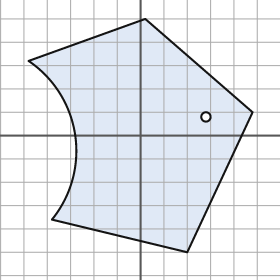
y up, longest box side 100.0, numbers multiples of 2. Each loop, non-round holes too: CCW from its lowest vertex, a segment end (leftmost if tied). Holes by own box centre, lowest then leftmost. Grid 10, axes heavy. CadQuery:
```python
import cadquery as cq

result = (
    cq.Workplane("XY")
    .moveTo(20.0, -50.0)
    .lineTo(48.0, 10.0)
    .lineTo(2.0, 50.0)
    .lineTo(-48.0, 32.0)
    .threePointArc((-28.0, 0.0), (-38.0, -36.0))
    .close()
    .moveTo(28.0, 8.0)
    .circle(2.0)
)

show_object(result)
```